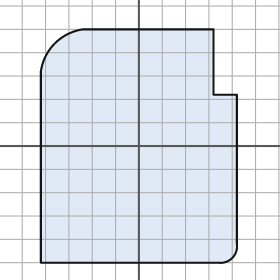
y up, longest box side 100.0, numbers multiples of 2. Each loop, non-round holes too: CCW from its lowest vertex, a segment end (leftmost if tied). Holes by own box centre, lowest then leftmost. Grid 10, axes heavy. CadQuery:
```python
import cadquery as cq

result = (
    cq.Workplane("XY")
    .moveTo(-42.0, -50.0)
    .lineTo(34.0, -50.0)
    .threePointArc((40.0, -48.0), (42.0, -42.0))
    .lineTo(42.0, 22.0)
    .lineTo(32.0, 22.0)
    .lineTo(32.0, 50.0)
    .lineTo(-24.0, 50.0)
    .threePointArc((-36.0, 44.0), (-42.0, 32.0))
    .close()
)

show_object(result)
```